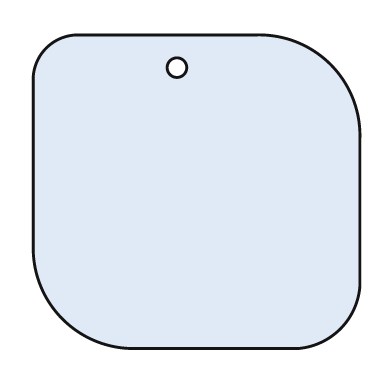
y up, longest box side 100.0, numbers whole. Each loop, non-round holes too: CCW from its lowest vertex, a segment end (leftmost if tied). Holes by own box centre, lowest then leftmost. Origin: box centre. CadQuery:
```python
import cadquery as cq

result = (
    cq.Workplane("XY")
    .moveTo(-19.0, -48.0)
    .lineTo(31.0, -48.0)
    .threePointArc((44.0, -42.0), (50.0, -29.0))
    .lineTo(50.0, 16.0)
    .threePointArc((41.0, 39.0), (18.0, 48.0))
    .lineTo(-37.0, 48.0)
    .threePointArc((-46.0, 44.0), (-50.0, 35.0))
    .lineTo(-50.0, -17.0)
    .threePointArc((-41.0, -39.0), (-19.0, -48.0))
    .close()
    .moveTo(-6.0, 38.0)
    .circle(3.0)
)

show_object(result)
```